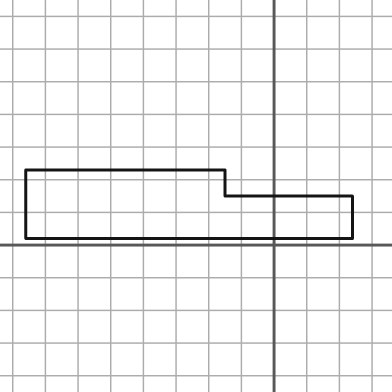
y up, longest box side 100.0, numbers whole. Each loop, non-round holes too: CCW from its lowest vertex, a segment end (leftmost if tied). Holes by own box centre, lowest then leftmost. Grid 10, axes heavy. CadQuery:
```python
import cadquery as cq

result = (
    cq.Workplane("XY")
    .moveTo(-76.0, 2.0)
    .lineTo(24.0, 2.0)
    .lineTo(24.0, 15.0)
    .lineTo(-15.0, 15.0)
    .lineTo(-15.0, 23.0)
    .lineTo(-76.0, 23.0)
    .close()
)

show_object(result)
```